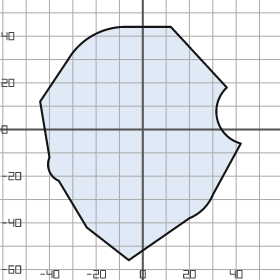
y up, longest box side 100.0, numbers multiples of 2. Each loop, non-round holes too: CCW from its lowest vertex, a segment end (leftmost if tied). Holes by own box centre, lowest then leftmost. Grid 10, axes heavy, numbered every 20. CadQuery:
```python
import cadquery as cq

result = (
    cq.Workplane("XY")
    .moveTo(-6.0, -56.0)
    .lineTo(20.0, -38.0)
    .threePointArc((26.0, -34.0), (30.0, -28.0))
    .lineTo(42.0, -6.0)
    .threePointArc((32.0, 4.0), (36.0, 18.0))
    .lineTo(12.0, 44.0)
    .lineTo(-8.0, 44.0)
    .threePointArc((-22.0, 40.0), (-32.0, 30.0))
    .lineTo(-44.0, 12.0)
    .lineTo(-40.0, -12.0)
    .threePointArc((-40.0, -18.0), (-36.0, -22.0))
    .lineTo(-24.0, -42.0)
    .close()
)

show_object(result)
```